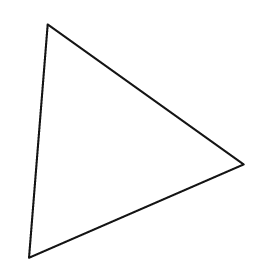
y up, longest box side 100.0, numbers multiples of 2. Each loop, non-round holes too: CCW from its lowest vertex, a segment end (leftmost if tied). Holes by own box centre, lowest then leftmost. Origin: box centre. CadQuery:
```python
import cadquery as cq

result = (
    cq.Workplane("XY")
    .moveTo(-46.0, -50.0)
    .lineTo(46.0, -10.0)
    .lineTo(-38.0, 50.0)
    .close()
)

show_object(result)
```